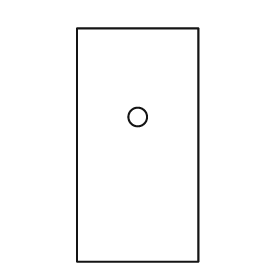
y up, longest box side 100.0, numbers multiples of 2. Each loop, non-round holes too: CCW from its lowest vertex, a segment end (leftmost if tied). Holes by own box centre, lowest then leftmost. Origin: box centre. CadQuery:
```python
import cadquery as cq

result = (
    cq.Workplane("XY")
    .moveTo(-26.0, -50.0)
    .lineTo(26.0, -50.0)
    .lineTo(26.0, 50.0)
    .lineTo(-26.0, 50.0)
    .close()
    .moveTo(0.0, 12.0)
    .circle(4.0)
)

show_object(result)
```